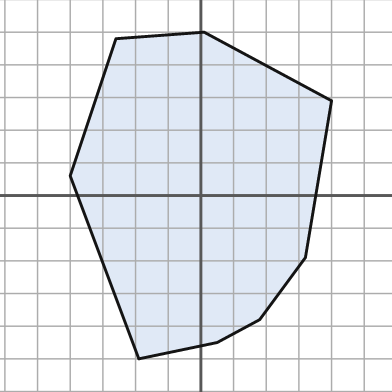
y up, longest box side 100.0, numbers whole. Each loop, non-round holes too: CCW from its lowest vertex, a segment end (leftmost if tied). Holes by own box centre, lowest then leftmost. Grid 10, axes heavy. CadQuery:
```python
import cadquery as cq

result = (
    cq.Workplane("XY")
    .moveTo(-19.0, -50.0)
    .lineTo(5.0, -45.0)
    .lineTo(18.0, -38.0)
    .lineTo(32.0, -19.0)
    .lineTo(40.0, 29.0)
    .lineTo(1.0, 50.0)
    .lineTo(-26.0, 48.0)
    .lineTo(-40.0, 6.0)
    .close()
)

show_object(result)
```